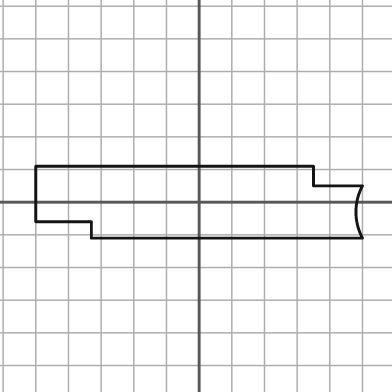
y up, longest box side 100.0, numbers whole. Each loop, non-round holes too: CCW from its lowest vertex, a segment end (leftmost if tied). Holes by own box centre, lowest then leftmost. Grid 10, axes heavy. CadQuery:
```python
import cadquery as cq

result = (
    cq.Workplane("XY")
    .moveTo(-33.0, -11.0)
    .lineTo(50.0, -11.0)
    .threePointArc((48.0, -3.0), (50.0, 5.0))
    .lineTo(35.0, 5.0)
    .lineTo(35.0, 11.0)
    .lineTo(-50.0, 11.0)
    .lineTo(-50.0, -6.0)
    .lineTo(-33.0, -6.0)
    .close()
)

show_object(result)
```